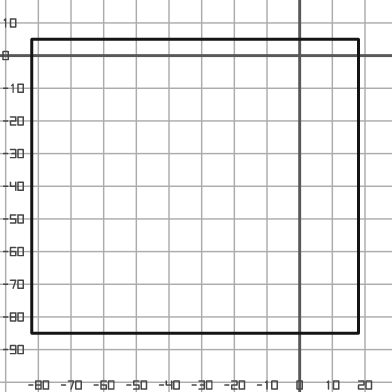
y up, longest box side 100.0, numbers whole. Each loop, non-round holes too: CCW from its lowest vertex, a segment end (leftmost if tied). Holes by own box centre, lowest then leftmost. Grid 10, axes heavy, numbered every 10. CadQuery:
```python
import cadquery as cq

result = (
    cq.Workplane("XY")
    .moveTo(-82.0, -85.0)
    .lineTo(18.0, -85.0)
    .lineTo(18.0, 5.0)
    .lineTo(-82.0, 5.0)
    .close()
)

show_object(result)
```